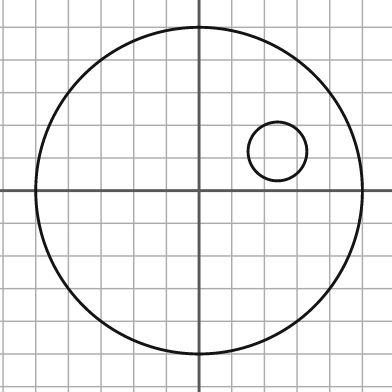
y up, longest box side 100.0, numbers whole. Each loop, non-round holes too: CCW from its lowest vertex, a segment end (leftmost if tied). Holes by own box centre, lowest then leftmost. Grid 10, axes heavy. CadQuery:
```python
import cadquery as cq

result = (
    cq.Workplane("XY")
    .moveTo(0.0, 0.0)
    .circle(50.0)
    .moveTo(24.0, 12.0)
    .circle(9.0)
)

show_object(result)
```